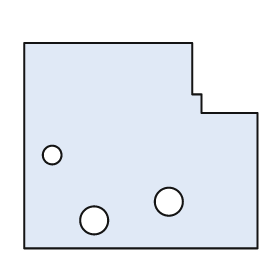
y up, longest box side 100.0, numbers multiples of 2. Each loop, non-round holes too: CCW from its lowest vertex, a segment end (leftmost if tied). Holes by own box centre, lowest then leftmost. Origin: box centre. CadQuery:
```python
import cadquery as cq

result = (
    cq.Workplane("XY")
    .moveTo(-50.0, -44.0)
    .lineTo(50.0, -44.0)
    .lineTo(50.0, 14.0)
    .lineTo(26.0, 14.0)
    .lineTo(26.0, 22.0)
    .lineTo(22.0, 22.0)
    .lineTo(22.0, 44.0)
    .lineTo(-50.0, 44.0)
    .close()
    .moveTo(-20.0, -32.0)
    .circle(6.0)
    .moveTo(12.0, -24.0)
    .circle(6.0)
    .moveTo(-38.0, -4.0)
    .circle(4.0)
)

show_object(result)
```